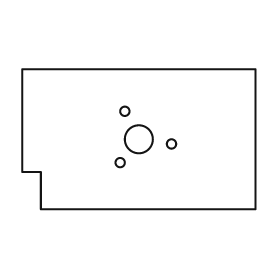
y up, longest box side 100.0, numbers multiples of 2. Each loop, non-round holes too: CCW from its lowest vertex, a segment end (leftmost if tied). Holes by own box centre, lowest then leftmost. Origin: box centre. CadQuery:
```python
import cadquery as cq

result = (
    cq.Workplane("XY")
    .moveTo(-42.0, -30.0)
    .lineTo(50.0, -30.0)
    .lineTo(50.0, 30.0)
    .lineTo(-50.0, 30.0)
    .lineTo(-50.0, -14.0)
    .lineTo(-42.0, -14.0)
    .close()
    .moveTo(-8.0, -10.0)
    .circle(2.0)
    .moveTo(14.0, -2.0)
    .circle(2.0)
    .moveTo(0.0, 0.0)
    .circle(6.0)
    .moveTo(-6.0, 12.0)
    .circle(2.0)
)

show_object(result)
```